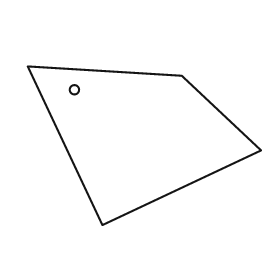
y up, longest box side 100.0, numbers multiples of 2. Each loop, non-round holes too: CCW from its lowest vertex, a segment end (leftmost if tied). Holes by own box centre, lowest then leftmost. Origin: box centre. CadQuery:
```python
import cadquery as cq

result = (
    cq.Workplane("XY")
    .moveTo(-18.0, -34.0)
    .lineTo(50.0, -2.0)
    .lineTo(16.0, 30.0)
    .lineTo(-50.0, 34.0)
    .close()
    .moveTo(-30.0, 24.0)
    .circle(2.0)
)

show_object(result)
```